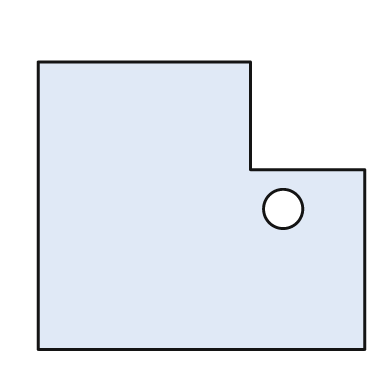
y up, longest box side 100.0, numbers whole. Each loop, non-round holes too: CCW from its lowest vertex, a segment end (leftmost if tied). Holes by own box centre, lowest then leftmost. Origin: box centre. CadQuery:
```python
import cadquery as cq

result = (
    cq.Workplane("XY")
    .moveTo(-50.0, -44.0)
    .lineTo(50.0, -44.0)
    .lineTo(50.0, 11.0)
    .lineTo(15.0, 11.0)
    .lineTo(15.0, 44.0)
    .lineTo(-50.0, 44.0)
    .close()
    .moveTo(25.0, -1.0)
    .circle(6.0)
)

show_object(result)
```